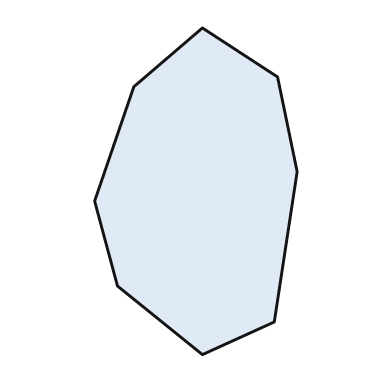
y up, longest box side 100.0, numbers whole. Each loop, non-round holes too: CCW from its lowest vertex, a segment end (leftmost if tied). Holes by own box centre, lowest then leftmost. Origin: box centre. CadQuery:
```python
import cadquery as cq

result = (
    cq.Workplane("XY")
    .moveTo(2.0, -50.0)
    .lineTo(24.0, -40.0)
    .lineTo(31.0, 6.0)
    .lineTo(25.0, 35.0)
    .lineTo(2.0, 50.0)
    .lineTo(-19.0, 32.0)
    .lineTo(-31.0, -3.0)
    .lineTo(-24.0, -29.0)
    .close()
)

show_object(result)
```